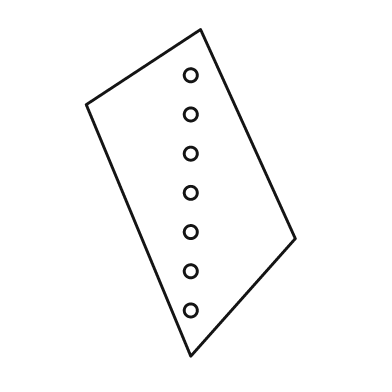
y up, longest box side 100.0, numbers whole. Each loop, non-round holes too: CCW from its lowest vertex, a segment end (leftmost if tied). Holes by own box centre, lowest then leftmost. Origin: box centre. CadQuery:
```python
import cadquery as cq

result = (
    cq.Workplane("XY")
    .moveTo(0.0, -50.0)
    .lineTo(32.0, -14.0)
    .lineTo(3.0, 50.0)
    .lineTo(-32.0, 27.0)
    .close()
    .moveTo(0.0, -36.0)
    .circle(2.0)
    .moveTo(0.0, -24.0)
    .circle(2.0)
    .moveTo(0.0, -12.0)
    .circle(2.0)
    .moveTo(0.0, 0.0)
    .circle(2.0)
    .moveTo(0.0, 12.0)
    .circle(2.0)
    .moveTo(0.0, 24.0)
    .circle(2.0)
    .moveTo(0.0, 36.0)
    .circle(2.0)
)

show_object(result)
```